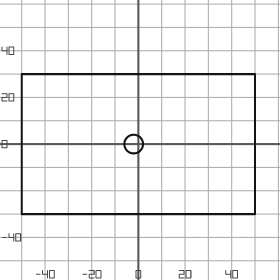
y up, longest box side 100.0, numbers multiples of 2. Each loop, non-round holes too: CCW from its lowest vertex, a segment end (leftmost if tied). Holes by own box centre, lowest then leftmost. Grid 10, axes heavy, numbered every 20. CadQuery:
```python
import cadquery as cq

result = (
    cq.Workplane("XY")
    .moveTo(-50.0, -30.0)
    .lineTo(50.0, -30.0)
    .lineTo(50.0, 30.0)
    .lineTo(-50.0, 30.0)
    .close()
    .moveTo(-2.0, 0.0)
    .circle(4.0)
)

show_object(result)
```